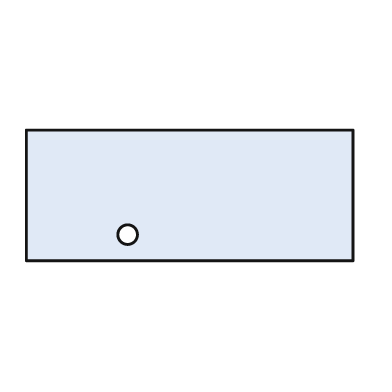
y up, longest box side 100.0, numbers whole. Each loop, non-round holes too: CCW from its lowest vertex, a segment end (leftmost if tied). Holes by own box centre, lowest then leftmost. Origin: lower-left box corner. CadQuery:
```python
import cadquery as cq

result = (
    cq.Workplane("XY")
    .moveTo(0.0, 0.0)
    .lineTo(100.0, 0.0)
    .lineTo(100.0, 40.0)
    .lineTo(0.0, 40.0)
    .close()
    .moveTo(31.0, 8.0)
    .circle(3.0)
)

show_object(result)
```